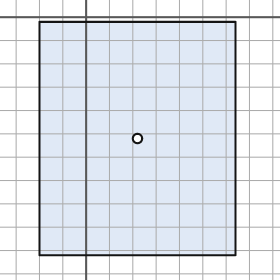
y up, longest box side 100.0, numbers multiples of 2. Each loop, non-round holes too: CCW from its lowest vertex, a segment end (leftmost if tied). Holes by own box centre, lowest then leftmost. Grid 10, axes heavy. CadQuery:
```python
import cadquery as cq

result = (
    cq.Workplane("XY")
    .moveTo(-20.0, -102.0)
    .lineTo(64.0, -102.0)
    .lineTo(64.0, -2.0)
    .lineTo(-20.0, -2.0)
    .close()
    .moveTo(22.0, -52.0)
    .circle(2.0)
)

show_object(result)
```